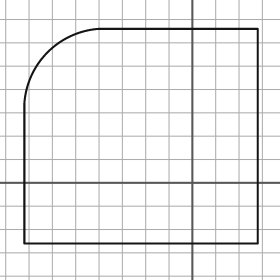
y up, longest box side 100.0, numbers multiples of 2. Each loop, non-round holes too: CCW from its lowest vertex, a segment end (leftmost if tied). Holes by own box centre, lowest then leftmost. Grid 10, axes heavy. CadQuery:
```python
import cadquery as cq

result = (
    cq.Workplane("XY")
    .moveTo(-72.0, -26.0)
    .lineTo(28.0, -26.0)
    .lineTo(28.0, 66.0)
    .lineTo(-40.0, 66.0)
    .threePointArc((-62.0, 56.0), (-72.0, 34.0))
    .close()
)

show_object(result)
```